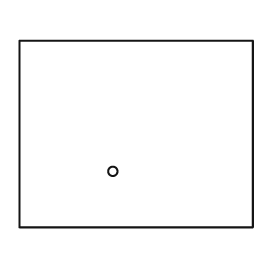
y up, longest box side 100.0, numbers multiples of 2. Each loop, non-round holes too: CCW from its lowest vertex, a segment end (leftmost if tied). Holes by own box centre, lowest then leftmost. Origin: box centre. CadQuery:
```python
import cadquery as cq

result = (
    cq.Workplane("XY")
    .moveTo(-50.0, -40.0)
    .lineTo(50.0, -40.0)
    .lineTo(50.0, 40.0)
    .lineTo(-50.0, 40.0)
    .close()
    .moveTo(-10.0, -16.0)
    .circle(2.0)
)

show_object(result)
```